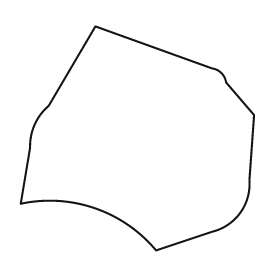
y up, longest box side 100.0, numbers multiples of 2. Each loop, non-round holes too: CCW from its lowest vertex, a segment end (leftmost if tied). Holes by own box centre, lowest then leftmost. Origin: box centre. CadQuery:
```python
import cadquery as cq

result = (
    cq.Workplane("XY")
    .moveTo(8.0, -48.0)
    .lineTo(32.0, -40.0)
    .threePointArc((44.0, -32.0), (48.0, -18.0))
    .lineTo(50.0, 10.0)
    .lineTo(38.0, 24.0)
    .threePointArc((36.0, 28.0), (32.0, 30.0))
    .lineTo(-18.0, 48.0)
    .lineTo(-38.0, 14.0)
    .threePointArc((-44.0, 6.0), (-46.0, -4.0))
    .lineTo(-50.0, -28.0)
    .threePointArc((-18.0, -30.0), (8.0, -48.0))
    .close()
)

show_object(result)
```